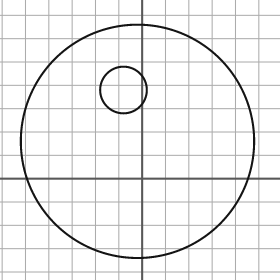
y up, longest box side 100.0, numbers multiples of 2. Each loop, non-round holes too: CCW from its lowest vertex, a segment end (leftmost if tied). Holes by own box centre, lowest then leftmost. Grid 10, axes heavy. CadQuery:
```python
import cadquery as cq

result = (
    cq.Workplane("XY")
    .moveTo(-2.0, 16.0)
    .circle(50.0)
    .moveTo(-8.0, 38.0)
    .circle(10.0)
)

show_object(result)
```